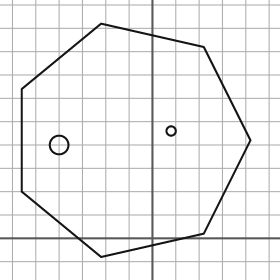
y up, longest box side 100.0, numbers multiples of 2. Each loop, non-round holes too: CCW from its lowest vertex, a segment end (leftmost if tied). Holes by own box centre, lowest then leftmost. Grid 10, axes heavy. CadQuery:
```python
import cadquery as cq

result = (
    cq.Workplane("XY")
    .moveTo(-22.0, -8.0)
    .lineTo(22.0, 2.0)
    .lineTo(42.0, 42.0)
    .lineTo(22.0, 82.0)
    .lineTo(-22.0, 92.0)
    .lineTo(-56.0, 64.0)
    .lineTo(-56.0, 20.0)
    .close()
    .moveTo(-40.0, 40.0)
    .circle(4.0)
    .moveTo(8.0, 46.0)
    .circle(2.0)
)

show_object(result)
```